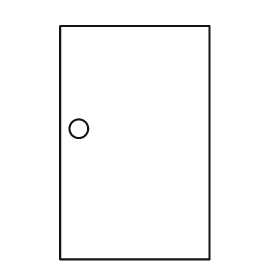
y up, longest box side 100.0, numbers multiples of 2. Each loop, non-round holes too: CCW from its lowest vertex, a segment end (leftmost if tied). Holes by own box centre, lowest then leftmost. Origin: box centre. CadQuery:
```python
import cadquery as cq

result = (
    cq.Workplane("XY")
    .moveTo(-32.0, -50.0)
    .lineTo(32.0, -50.0)
    .lineTo(32.0, 50.0)
    .lineTo(-32.0, 50.0)
    .close()
    .moveTo(-24.0, 6.0)
    .circle(4.0)
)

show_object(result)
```